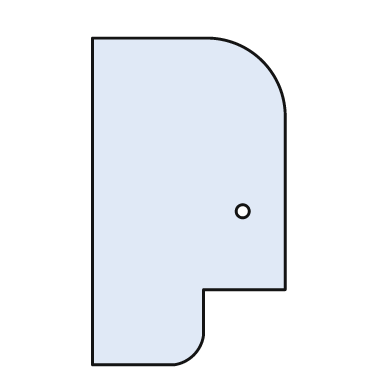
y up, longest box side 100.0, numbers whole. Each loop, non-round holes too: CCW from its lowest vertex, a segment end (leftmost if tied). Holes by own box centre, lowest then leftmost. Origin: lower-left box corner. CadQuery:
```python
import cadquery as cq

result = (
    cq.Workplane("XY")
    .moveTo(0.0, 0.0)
    .lineTo(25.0, 0.0)
    .threePointArc((31.0, 3.0), (34.0, 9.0))
    .lineTo(34.0, 23.0)
    .lineTo(59.0, 23.0)
    .lineTo(59.0, 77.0)
    .threePointArc((52.0, 93.0), (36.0, 100.0))
    .lineTo(0.0, 100.0)
    .close()
    .moveTo(46.0, 47.0)
    .circle(2.0)
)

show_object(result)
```